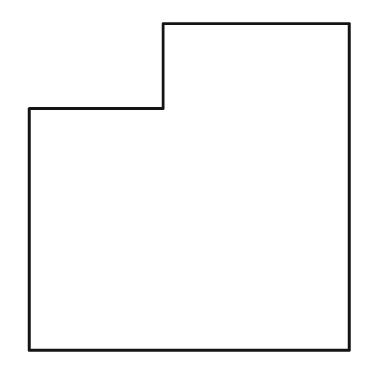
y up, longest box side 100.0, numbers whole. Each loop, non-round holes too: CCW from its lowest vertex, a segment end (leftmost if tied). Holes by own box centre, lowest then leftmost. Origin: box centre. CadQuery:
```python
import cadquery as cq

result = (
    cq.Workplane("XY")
    .moveTo(-49.0, -50.0)
    .lineTo(49.0, -50.0)
    .lineTo(49.0, 50.0)
    .lineTo(-8.0, 50.0)
    .lineTo(-8.0, 24.0)
    .lineTo(-49.0, 24.0)
    .close()
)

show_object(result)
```